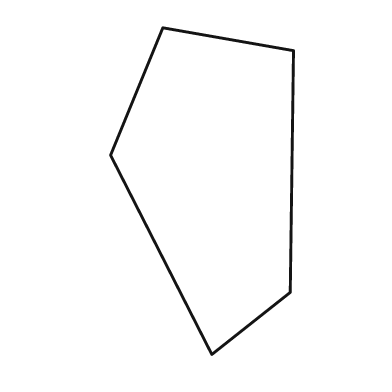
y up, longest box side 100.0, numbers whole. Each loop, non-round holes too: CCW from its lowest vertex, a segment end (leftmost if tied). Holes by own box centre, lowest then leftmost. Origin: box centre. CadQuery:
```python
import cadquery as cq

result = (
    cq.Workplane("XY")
    .moveTo(3.0, -50.0)
    .lineTo(27.0, -31.0)
    .lineTo(28.0, 43.0)
    .lineTo(-12.0, 50.0)
    .lineTo(-28.0, 11.0)
    .close()
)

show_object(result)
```